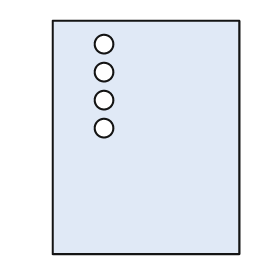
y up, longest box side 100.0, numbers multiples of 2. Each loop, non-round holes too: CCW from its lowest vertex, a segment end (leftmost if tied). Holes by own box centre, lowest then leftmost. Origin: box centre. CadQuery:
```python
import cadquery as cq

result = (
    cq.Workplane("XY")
    .moveTo(-40.0, -50.0)
    .lineTo(40.0, -50.0)
    .lineTo(40.0, 50.0)
    .lineTo(-40.0, 50.0)
    .close()
    .moveTo(-18.0, 4.0)
    .circle(4.0)
    .moveTo(-18.0, 16.0)
    .circle(4.0)
    .moveTo(-18.0, 28.0)
    .circle(4.0)
    .moveTo(-18.0, 40.0)
    .circle(4.0)
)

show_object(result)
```